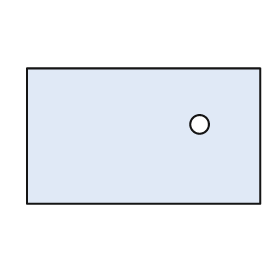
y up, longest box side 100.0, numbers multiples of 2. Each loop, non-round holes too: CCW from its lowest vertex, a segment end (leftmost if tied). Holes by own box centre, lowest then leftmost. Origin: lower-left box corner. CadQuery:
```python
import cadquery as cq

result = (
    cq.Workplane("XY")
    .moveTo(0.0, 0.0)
    .lineTo(100.0, 0.0)
    .lineTo(100.0, 58.0)
    .lineTo(0.0, 58.0)
    .close()
    .moveTo(74.0, 34.0)
    .circle(4.0)
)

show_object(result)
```